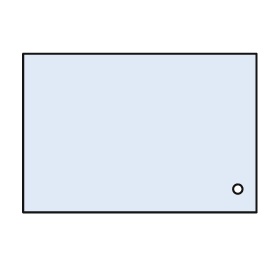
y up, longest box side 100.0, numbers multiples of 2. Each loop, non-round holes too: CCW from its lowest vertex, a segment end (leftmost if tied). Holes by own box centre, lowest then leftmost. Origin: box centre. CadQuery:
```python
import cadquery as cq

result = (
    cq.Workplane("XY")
    .moveTo(-50.0, -34.0)
    .lineTo(50.0, -34.0)
    .lineTo(50.0, 34.0)
    .lineTo(-50.0, 34.0)
    .close()
    .moveTo(42.0, -24.0)
    .circle(2.0)
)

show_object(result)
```